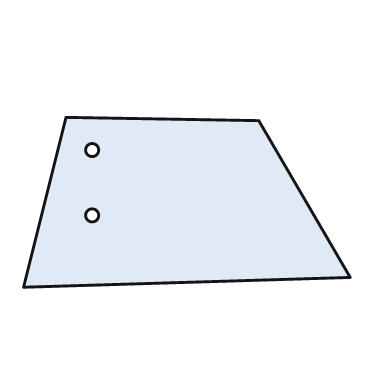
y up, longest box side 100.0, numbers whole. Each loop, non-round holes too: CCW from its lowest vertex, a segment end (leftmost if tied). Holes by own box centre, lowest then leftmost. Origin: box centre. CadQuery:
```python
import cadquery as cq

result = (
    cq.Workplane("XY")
    .moveTo(-50.0, -26.0)
    .lineTo(50.0, -23.0)
    .lineTo(22.0, 25.0)
    .lineTo(-37.0, 26.0)
    .close()
    .moveTo(-29.0, -4.0)
    .circle(2.0)
    .moveTo(-29.0, 16.0)
    .circle(2.0)
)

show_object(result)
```